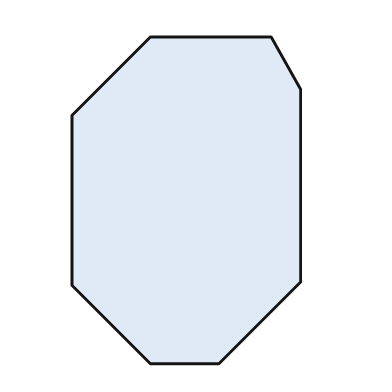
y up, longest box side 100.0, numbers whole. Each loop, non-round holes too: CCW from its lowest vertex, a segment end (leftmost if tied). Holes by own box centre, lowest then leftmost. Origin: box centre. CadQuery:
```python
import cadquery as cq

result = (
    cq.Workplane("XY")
    .moveTo(-11.0, -50.0)
    .lineTo(10.0, -50.0)
    .lineTo(35.0, -25.0)
    .lineTo(35.0, 34.0)
    .lineTo(26.0, 50.0)
    .lineTo(-11.0, 50.0)
    .lineTo(-35.0, 26.0)
    .lineTo(-35.0, -26.0)
    .close()
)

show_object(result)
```